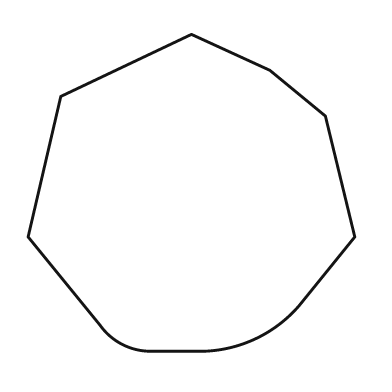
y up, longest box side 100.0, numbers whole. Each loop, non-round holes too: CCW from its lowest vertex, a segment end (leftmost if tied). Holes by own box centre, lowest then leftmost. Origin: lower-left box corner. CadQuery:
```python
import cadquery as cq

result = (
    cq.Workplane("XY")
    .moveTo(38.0, 0.0)
    .lineTo(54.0, 0.0)
    .threePointArc((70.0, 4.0), (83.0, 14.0))
    .lineTo(100.0, 35.0)
    .lineTo(91.0, 72.0)
    .lineTo(74.0, 86.0)
    .lineTo(50.0, 97.0)
    .lineTo(10.0, 78.0)
    .lineTo(0.0, 35.0)
    .lineTo(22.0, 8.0)
    .threePointArc((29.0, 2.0), (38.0, 0.0))
    .close()
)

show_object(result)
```